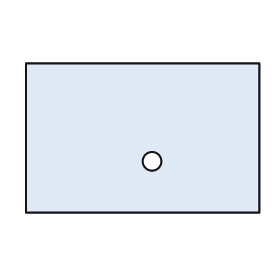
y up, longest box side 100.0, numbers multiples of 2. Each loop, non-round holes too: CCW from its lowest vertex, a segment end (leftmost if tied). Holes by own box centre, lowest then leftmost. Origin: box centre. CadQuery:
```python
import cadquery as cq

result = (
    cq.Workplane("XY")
    .moveTo(-50.0, -32.0)
    .lineTo(50.0, -32.0)
    .lineTo(50.0, 32.0)
    .lineTo(-50.0, 32.0)
    .close()
    .moveTo(4.0, -10.0)
    .circle(4.0)
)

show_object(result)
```